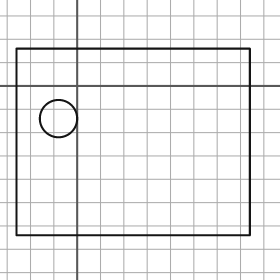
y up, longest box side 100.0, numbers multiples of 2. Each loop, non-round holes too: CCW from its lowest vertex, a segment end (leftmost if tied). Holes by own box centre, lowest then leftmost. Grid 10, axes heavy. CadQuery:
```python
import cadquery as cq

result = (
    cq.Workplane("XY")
    .moveTo(-26.0, -64.0)
    .lineTo(74.0, -64.0)
    .lineTo(74.0, 16.0)
    .lineTo(-26.0, 16.0)
    .close()
    .moveTo(-8.0, -14.0)
    .circle(8.0)
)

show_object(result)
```